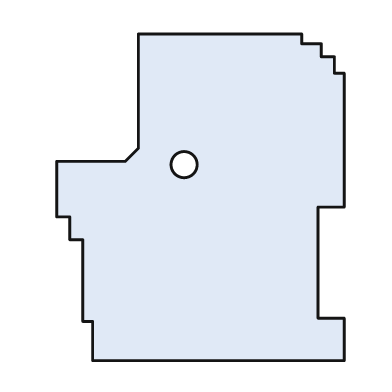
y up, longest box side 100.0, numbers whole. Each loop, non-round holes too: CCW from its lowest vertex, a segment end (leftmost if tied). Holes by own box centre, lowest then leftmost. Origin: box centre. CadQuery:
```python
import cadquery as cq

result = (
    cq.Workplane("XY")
    .moveTo(-33.0, -50.0)
    .lineTo(44.0, -50.0)
    .lineTo(44.0, -37.0)
    .lineTo(36.0, -37.0)
    .lineTo(36.0, -3.0)
    .lineTo(44.0, -3.0)
    .lineTo(44.0, 38.0)
    .lineTo(41.0, 38.0)
    .lineTo(41.0, 43.0)
    .lineTo(37.0, 43.0)
    .lineTo(37.0, 47.0)
    .lineTo(31.0, 47.0)
    .lineTo(31.0, 50.0)
    .lineTo(-19.0, 50.0)
    .lineTo(-19.0, 15.0)
    .lineTo(-23.0, 11.0)
    .lineTo(-44.0, 11.0)
    .lineTo(-44.0, -6.0)
    .lineTo(-40.0, -6.0)
    .lineTo(-40.0, -13.0)
    .lineTo(-36.0, -13.0)
    .lineTo(-36.0, -38.0)
    .lineTo(-33.0, -38.0)
    .close()
    .moveTo(-5.0, 10.0)
    .circle(4.0)
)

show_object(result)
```